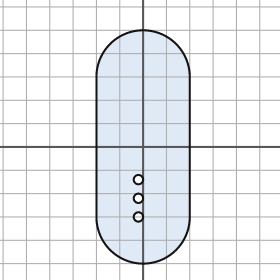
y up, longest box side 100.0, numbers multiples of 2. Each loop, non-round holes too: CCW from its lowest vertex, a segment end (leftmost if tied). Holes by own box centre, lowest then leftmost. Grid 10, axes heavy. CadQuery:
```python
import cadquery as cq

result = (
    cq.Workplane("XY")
    .moveTo(-20.0, -30.0)
    .threePointArc((0.0, -50.0), (20.0, -30.0))
    .lineTo(20.0, 30.0)
    .threePointArc((0.0, 50.0), (-20.0, 30.0))
    .close()
    .moveTo(-2.0, -30.0)
    .circle(2.0)
    .moveTo(-2.0, -22.0)
    .circle(2.0)
    .moveTo(-2.0, -14.0)
    .circle(2.0)
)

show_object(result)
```